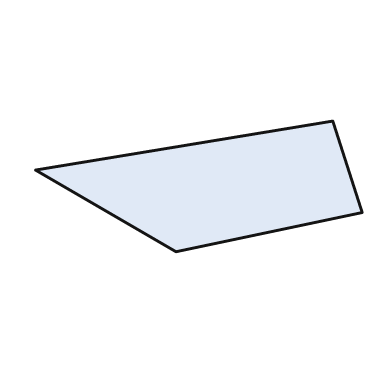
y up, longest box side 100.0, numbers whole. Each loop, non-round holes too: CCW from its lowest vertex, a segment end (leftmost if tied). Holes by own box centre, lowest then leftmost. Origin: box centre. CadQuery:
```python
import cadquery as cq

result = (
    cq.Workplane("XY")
    .moveTo(-7.0, -20.0)
    .lineTo(50.0, -8.0)
    .lineTo(41.0, 20.0)
    .lineTo(-50.0, 5.0)
    .close()
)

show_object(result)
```